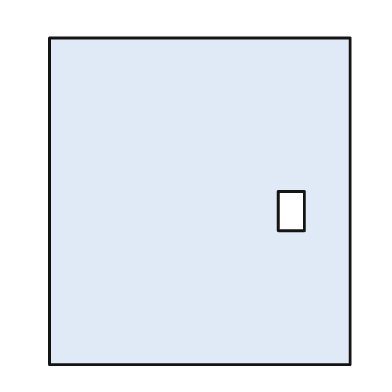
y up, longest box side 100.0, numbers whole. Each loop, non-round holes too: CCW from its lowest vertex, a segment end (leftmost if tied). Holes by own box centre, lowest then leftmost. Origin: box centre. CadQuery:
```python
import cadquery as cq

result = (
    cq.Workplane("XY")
    .moveTo(-46.0, -50.0)
    .lineTo(46.0, -50.0)
    .lineTo(46.0, 50.0)
    .lineTo(-46.0, 50.0)
    .close()
    .moveTo(24.0, -9.0)
    .lineTo(32.0, -9.0)
    .lineTo(32.0, 3.0)
    .lineTo(24.0, 3.0)
    .close()
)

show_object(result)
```